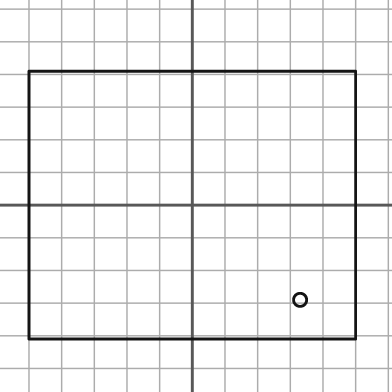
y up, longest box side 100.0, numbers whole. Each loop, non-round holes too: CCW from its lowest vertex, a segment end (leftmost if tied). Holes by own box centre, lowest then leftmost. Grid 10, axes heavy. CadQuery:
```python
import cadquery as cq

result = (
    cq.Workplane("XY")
    .moveTo(-50.0, -41.0)
    .lineTo(50.0, -41.0)
    .lineTo(50.0, 41.0)
    .lineTo(-50.0, 41.0)
    .close()
    .moveTo(33.0, -29.0)
    .circle(2.0)
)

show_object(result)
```